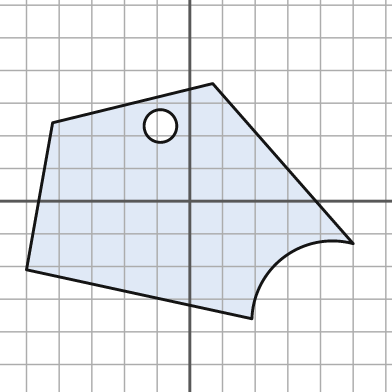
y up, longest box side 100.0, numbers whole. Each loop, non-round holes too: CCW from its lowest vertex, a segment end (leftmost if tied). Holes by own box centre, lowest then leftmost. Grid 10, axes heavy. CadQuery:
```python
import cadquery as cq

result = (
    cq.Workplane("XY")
    .moveTo(19.0, -36.0)
    .threePointArc((29.0, -17.0), (50.0, -13.0))
    .lineTo(7.0, 36.0)
    .lineTo(-42.0, 24.0)
    .lineTo(-50.0, -21.0)
    .close()
    .moveTo(-9.0, 23.0)
    .circle(5.0)
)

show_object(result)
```